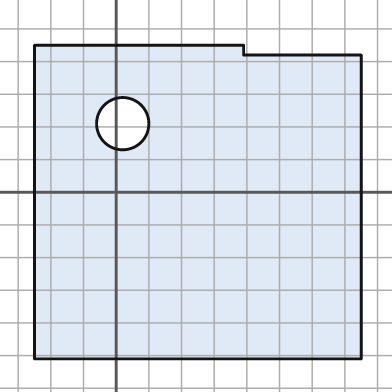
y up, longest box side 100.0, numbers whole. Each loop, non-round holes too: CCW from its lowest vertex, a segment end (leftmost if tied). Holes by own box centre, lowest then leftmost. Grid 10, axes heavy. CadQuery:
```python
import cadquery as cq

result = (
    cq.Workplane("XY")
    .moveTo(-25.0, -51.0)
    .lineTo(75.0, -51.0)
    .lineTo(75.0, 42.0)
    .lineTo(39.0, 42.0)
    .lineTo(39.0, 45.0)
    .lineTo(-25.0, 45.0)
    .close()
    .moveTo(2.0, 21.0)
    .circle(8.0)
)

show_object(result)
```